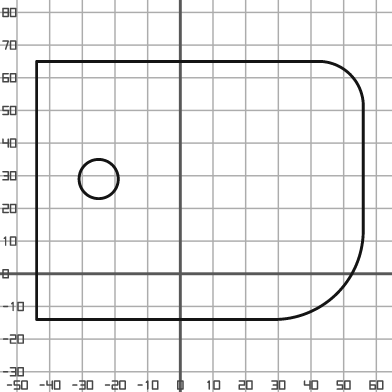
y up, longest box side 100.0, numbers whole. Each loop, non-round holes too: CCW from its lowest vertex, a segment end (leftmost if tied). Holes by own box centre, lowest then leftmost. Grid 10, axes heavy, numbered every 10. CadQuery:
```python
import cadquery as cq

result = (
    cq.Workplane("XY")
    .moveTo(-44.0, -14.0)
    .lineTo(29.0, -14.0)
    .threePointArc((48.0, -6.0), (56.0, 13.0))
    .lineTo(56.0, 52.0)
    .threePointArc((52.0, 61.0), (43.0, 65.0))
    .lineTo(-44.0, 65.0)
    .close()
    .moveTo(-25.0, 29.0)
    .circle(6.0)
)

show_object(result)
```